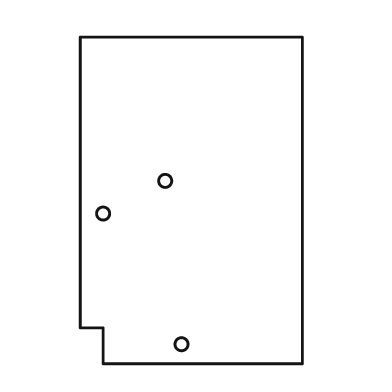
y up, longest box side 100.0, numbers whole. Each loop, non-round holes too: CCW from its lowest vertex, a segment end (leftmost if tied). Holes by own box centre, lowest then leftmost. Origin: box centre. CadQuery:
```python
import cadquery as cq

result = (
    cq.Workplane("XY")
    .moveTo(-27.0, -50.0)
    .lineTo(34.0, -50.0)
    .lineTo(34.0, 50.0)
    .lineTo(-34.0, 50.0)
    .lineTo(-34.0, -39.0)
    .lineTo(-27.0, -39.0)
    .close()
    .moveTo(-3.0, -44.0)
    .circle(2.0)
    .moveTo(-27.0, -4.0)
    .circle(2.0)
    .moveTo(-8.0, 6.0)
    .circle(2.0)
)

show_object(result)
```